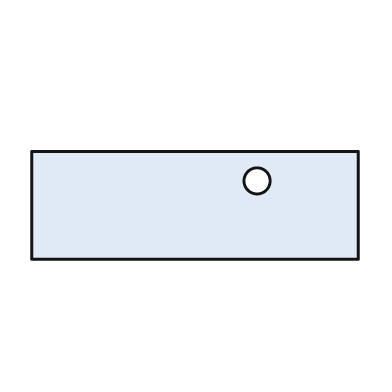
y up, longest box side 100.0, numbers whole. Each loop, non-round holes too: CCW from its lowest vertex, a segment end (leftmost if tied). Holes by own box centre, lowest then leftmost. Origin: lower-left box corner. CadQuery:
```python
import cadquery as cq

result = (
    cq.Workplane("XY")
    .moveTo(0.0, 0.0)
    .lineTo(100.0, 0.0)
    .lineTo(100.0, 33.0)
    .lineTo(0.0, 33.0)
    .close()
    .moveTo(69.0, 24.0)
    .circle(4.0)
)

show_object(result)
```